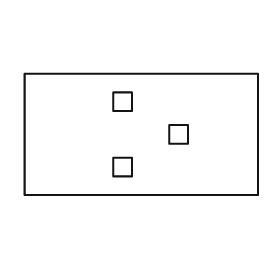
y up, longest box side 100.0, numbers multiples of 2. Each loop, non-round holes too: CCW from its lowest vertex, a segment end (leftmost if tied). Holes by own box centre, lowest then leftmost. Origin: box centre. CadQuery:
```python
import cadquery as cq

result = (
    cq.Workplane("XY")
    .moveTo(-50.0, -26.0)
    .lineTo(50.0, -26.0)
    .lineTo(50.0, 26.0)
    .lineTo(-50.0, 26.0)
    .close()
    .moveTo(-12.0, -18.0)
    .lineTo(-4.0, -18.0)
    .lineTo(-4.0, -10.0)
    .lineTo(-12.0, -10.0)
    .close()
    .moveTo(12.0, -4.0)
    .lineTo(20.0, -4.0)
    .lineTo(20.0, 4.0)
    .lineTo(12.0, 4.0)
    .close()
    .moveTo(-12.0, 10.0)
    .lineTo(-4.0, 10.0)
    .lineTo(-4.0, 18.0)
    .lineTo(-12.0, 18.0)
    .close()
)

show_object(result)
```